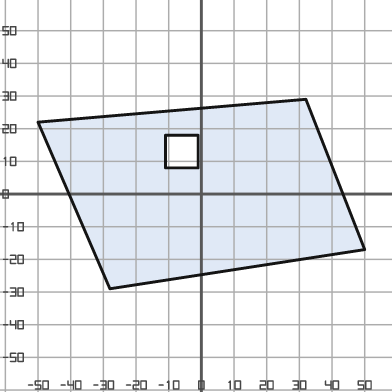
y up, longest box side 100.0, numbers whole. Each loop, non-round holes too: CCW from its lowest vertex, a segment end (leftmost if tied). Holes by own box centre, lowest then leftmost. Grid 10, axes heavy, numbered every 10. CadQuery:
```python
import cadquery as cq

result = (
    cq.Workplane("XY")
    .moveTo(-28.0, -29.0)
    .lineTo(50.0, -17.0)
    .lineTo(32.0, 29.0)
    .lineTo(-50.0, 22.0)
    .close()
    .moveTo(-11.0, 8.0)
    .lineTo(-1.0, 8.0)
    .lineTo(-1.0, 18.0)
    .lineTo(-11.0, 18.0)
    .close()
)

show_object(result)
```